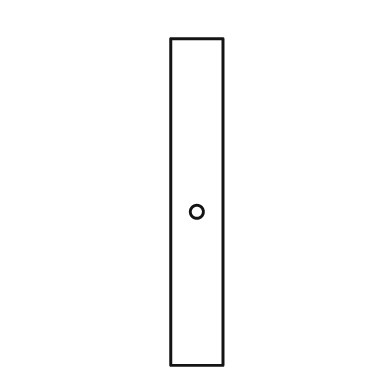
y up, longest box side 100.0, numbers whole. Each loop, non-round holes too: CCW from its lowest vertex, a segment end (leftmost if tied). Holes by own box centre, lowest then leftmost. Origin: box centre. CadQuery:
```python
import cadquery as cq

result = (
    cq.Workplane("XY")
    .moveTo(-8.0, -50.0)
    .lineTo(8.0, -50.0)
    .lineTo(8.0, 50.0)
    .lineTo(-8.0, 50.0)
    .close()
    .moveTo(0.0, -3.0)
    .circle(2.0)
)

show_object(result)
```